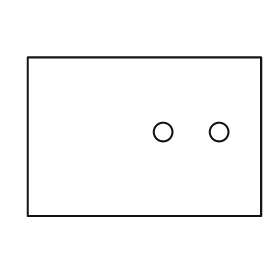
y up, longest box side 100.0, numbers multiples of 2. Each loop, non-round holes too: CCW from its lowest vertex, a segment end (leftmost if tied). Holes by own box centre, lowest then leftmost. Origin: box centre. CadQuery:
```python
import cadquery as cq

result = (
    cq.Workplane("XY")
    .moveTo(-50.0, -34.0)
    .lineTo(50.0, -34.0)
    .lineTo(50.0, 34.0)
    .lineTo(-50.0, 34.0)
    .close()
    .moveTo(8.0, 2.0)
    .circle(4.0)
    .moveTo(32.0, 2.0)
    .circle(4.0)
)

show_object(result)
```